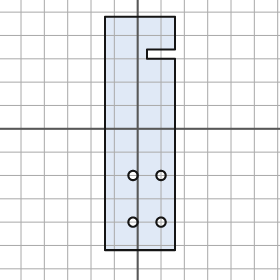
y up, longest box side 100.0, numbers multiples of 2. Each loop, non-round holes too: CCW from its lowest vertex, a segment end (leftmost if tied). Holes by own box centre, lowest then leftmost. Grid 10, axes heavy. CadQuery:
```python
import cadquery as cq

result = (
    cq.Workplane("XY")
    .moveTo(-14.0, -52.0)
    .lineTo(16.0, -52.0)
    .lineTo(16.0, 30.0)
    .lineTo(4.0, 30.0)
    .lineTo(4.0, 34.0)
    .lineTo(16.0, 34.0)
    .lineTo(16.0, 48.0)
    .lineTo(-14.0, 48.0)
    .close()
    .moveTo(-2.0, -40.0)
    .circle(2.0)
    .moveTo(10.0, -40.0)
    .circle(2.0)
    .moveTo(-2.0, -20.0)
    .circle(2.0)
    .moveTo(10.0, -20.0)
    .circle(2.0)
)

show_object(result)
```